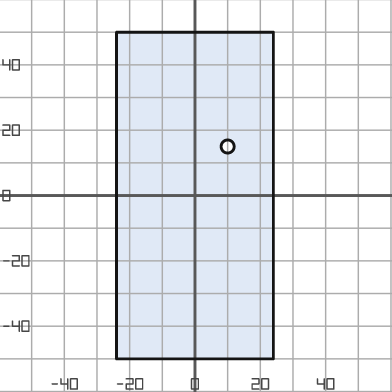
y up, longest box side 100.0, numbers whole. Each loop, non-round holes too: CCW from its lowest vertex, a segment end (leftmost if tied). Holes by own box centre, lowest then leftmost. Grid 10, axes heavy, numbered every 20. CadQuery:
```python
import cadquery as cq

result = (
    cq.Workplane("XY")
    .moveTo(-24.0, -50.0)
    .lineTo(24.0, -50.0)
    .lineTo(24.0, 50.0)
    .lineTo(-24.0, 50.0)
    .close()
    .moveTo(10.0, 15.0)
    .circle(2.0)
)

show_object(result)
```